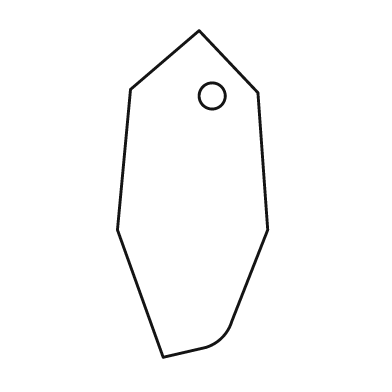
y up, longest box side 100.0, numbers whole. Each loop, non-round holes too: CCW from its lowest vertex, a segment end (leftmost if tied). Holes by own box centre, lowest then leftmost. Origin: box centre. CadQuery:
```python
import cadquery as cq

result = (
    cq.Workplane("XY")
    .moveTo(-9.0, -50.0)
    .lineTo(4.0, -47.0)
    .threePointArc((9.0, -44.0), (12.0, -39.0))
    .lineTo(23.0, -11.0)
    .lineTo(20.0, 31.0)
    .lineTo(2.0, 50.0)
    .lineTo(-19.0, 32.0)
    .lineTo(-23.0, -11.0)
    .close()
    .moveTo(6.0, 30.0)
    .circle(4.0)
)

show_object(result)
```